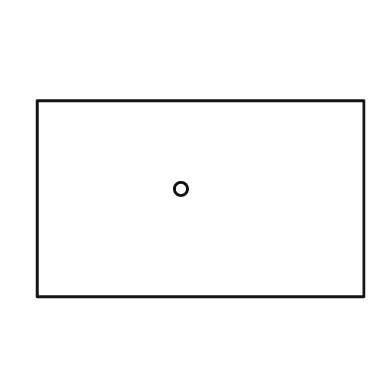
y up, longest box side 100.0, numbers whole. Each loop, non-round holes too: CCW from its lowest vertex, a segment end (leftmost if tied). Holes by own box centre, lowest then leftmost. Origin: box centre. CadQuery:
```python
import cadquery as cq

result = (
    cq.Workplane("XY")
    .moveTo(-50.0, -30.0)
    .lineTo(50.0, -30.0)
    .lineTo(50.0, 30.0)
    .lineTo(-50.0, 30.0)
    .close()
    .moveTo(-6.0, 3.0)
    .circle(2.0)
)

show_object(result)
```